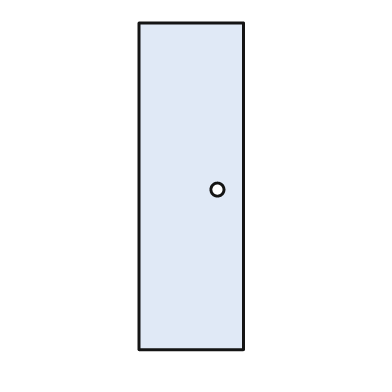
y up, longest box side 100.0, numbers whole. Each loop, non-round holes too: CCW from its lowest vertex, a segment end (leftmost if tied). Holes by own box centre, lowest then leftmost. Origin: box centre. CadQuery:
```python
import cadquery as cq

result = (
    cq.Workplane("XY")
    .moveTo(-16.0, -50.0)
    .lineTo(16.0, -50.0)
    .lineTo(16.0, 50.0)
    .lineTo(-16.0, 50.0)
    .close()
    .moveTo(8.0, -1.0)
    .circle(2.0)
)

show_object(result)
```